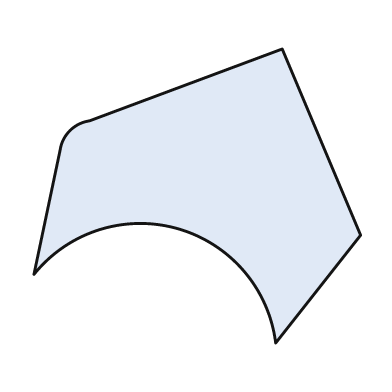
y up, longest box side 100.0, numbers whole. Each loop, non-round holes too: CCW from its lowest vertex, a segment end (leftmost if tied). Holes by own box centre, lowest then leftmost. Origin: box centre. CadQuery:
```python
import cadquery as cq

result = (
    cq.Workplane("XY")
    .moveTo(24.0, -45.0)
    .lineTo(50.0, -12.0)
    .lineTo(26.0, 45.0)
    .lineTo(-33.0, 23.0)
    .threePointArc((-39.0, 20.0), (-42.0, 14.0))
    .lineTo(-50.0, -24.0)
    .threePointArc((-6.0, -10.0), (24.0, -45.0))
    .close()
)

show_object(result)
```